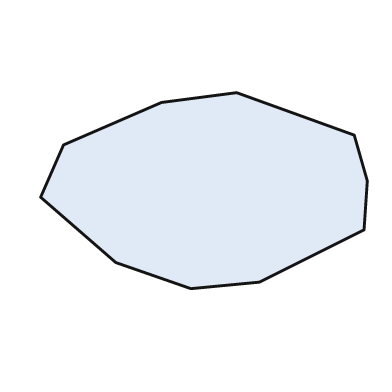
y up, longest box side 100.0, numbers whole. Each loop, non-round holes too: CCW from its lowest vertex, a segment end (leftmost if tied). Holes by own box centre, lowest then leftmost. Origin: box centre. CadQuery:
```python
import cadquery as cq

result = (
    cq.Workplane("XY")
    .moveTo(-4.0, -30.0)
    .lineTo(17.0, -28.0)
    .lineTo(49.0, -12.0)
    .lineTo(50.0, 3.0)
    .lineTo(46.0, 17.0)
    .lineTo(10.0, 30.0)
    .lineTo(-13.0, 27.0)
    .lineTo(-43.0, 14.0)
    .lineTo(-50.0, -2.0)
    .lineTo(-27.0, -22.0)
    .close()
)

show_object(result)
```